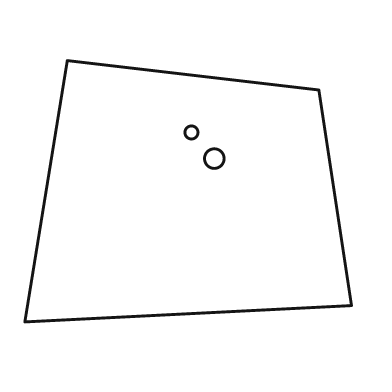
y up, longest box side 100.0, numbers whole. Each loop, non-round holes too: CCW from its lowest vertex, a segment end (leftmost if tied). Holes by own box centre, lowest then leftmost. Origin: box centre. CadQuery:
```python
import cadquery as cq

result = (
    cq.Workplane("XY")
    .moveTo(-50.0, -40.0)
    .lineTo(50.0, -35.0)
    .lineTo(40.0, 31.0)
    .lineTo(-37.0, 40.0)
    .close()
    .moveTo(8.0, 10.0)
    .circle(3.0)
    .moveTo(1.0, 18.0)
    .circle(2.0)
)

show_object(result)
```